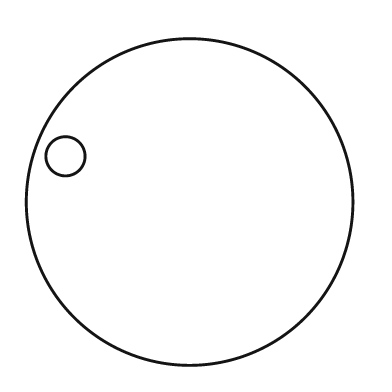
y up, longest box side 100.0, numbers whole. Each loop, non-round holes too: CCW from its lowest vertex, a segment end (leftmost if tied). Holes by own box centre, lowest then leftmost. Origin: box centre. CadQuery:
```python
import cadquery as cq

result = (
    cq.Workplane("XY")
    .moveTo(0.0, 0.0)
    .circle(50.0)
    .moveTo(-38.0, 14.0)
    .circle(6.0)
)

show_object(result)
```